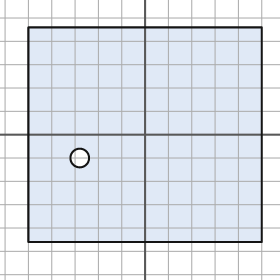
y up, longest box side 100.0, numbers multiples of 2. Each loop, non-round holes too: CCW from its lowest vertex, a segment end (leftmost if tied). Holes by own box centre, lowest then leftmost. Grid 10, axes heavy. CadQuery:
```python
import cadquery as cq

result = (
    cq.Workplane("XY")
    .moveTo(-50.0, -46.0)
    .lineTo(50.0, -46.0)
    .lineTo(50.0, 46.0)
    .lineTo(-50.0, 46.0)
    .close()
    .moveTo(-28.0, -10.0)
    .circle(4.0)
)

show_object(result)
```